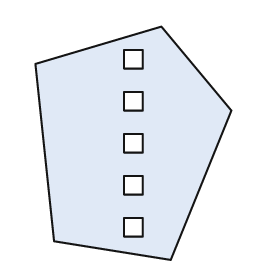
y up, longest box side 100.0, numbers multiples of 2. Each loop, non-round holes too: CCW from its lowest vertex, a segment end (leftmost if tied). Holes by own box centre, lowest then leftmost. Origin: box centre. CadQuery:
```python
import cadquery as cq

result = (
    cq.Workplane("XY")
    .moveTo(16.0, -50.0)
    .lineTo(42.0, 14.0)
    .lineTo(12.0, 50.0)
    .lineTo(-42.0, 34.0)
    .lineTo(-34.0, -42.0)
    .close()
    .moveTo(-4.0, -40.0)
    .lineTo(4.0, -40.0)
    .lineTo(4.0, -32.0)
    .lineTo(-4.0, -32.0)
    .close()
    .moveTo(-4.0, -22.0)
    .lineTo(4.0, -22.0)
    .lineTo(4.0, -14.0)
    .lineTo(-4.0, -14.0)
    .close()
    .moveTo(-4.0, -4.0)
    .lineTo(4.0, -4.0)
    .lineTo(4.0, 4.0)
    .lineTo(-4.0, 4.0)
    .close()
    .moveTo(-4.0, 14.0)
    .lineTo(4.0, 14.0)
    .lineTo(4.0, 22.0)
    .lineTo(-4.0, 22.0)
    .close()
    .moveTo(-4.0, 32.0)
    .lineTo(4.0, 32.0)
    .lineTo(4.0, 40.0)
    .lineTo(-4.0, 40.0)
    .close()
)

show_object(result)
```